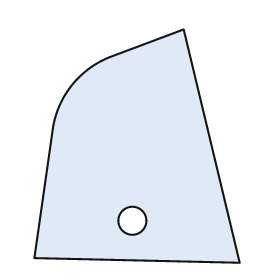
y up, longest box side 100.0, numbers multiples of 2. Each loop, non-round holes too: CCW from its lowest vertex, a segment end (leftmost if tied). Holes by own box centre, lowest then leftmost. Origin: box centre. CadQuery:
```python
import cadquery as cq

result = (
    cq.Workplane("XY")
    .moveTo(44.0, -50.0)
    .lineTo(20.0, 50.0)
    .lineTo(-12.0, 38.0)
    .threePointArc((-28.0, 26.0), (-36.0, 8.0))
    .lineTo(-44.0, -48.0)
    .close()
    .moveTo(-2.0, -32.0)
    .circle(6.0)
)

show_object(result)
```